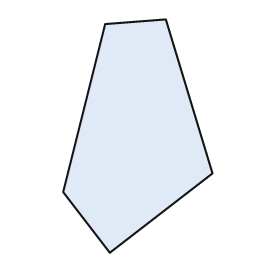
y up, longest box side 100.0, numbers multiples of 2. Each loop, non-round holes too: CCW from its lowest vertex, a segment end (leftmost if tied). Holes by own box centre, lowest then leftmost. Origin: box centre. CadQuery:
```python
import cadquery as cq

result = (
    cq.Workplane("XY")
    .moveTo(-12.0, -50.0)
    .lineTo(32.0, -16.0)
    .lineTo(12.0, 50.0)
    .lineTo(-14.0, 48.0)
    .lineTo(-32.0, -24.0)
    .close()
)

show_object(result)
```